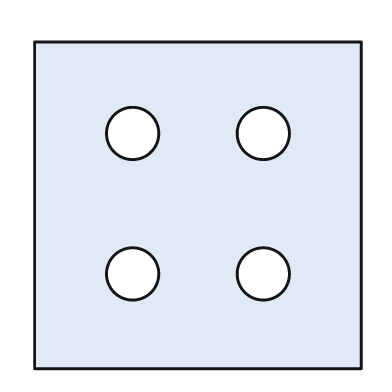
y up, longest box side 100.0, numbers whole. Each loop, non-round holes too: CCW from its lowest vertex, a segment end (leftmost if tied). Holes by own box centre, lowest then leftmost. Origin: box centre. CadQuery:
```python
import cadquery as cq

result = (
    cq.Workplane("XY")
    .moveTo(-50.0, -50.0)
    .lineTo(50.0, -50.0)
    .lineTo(50.0, 50.0)
    .lineTo(-50.0, 50.0)
    .close()
    .moveTo(-20.0, -21.0)
    .circle(8.0)
    .moveTo(20.0, -21.0)
    .circle(8.0)
    .moveTo(-20.0, 22.0)
    .circle(8.0)
    .moveTo(20.0, 22.0)
    .circle(8.0)
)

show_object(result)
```